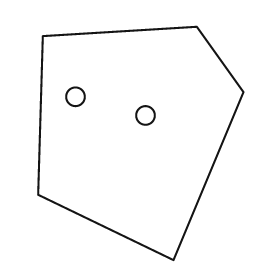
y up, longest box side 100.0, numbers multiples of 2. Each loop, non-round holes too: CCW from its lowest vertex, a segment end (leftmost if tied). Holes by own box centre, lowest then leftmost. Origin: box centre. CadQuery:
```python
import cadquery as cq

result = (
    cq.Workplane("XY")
    .moveTo(14.0, -50.0)
    .lineTo(44.0, 22.0)
    .lineTo(24.0, 50.0)
    .lineTo(-42.0, 46.0)
    .lineTo(-44.0, -22.0)
    .close()
    .moveTo(2.0, 12.0)
    .circle(4.0)
    .moveTo(-28.0, 20.0)
    .circle(4.0)
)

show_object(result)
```